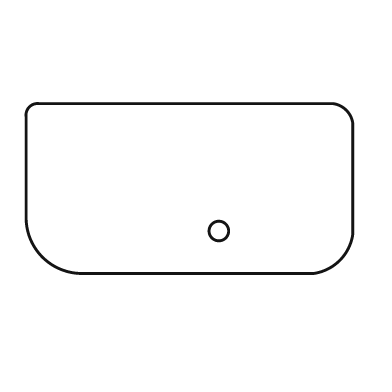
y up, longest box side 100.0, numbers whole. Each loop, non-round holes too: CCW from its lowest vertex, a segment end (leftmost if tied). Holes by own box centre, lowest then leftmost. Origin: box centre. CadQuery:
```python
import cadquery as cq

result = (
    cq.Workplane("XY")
    .moveTo(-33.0, -26.0)
    .lineTo(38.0, -26.0)
    .threePointArc((46.0, -22.0), (50.0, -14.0))
    .lineTo(50.0, 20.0)
    .threePointArc((48.0, 24.0), (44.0, 26.0))
    .lineTo(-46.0, 26.0)
    .threePointArc((-49.0, 25.0), (-50.0, 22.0))
    .lineTo(-50.0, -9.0)
    .threePointArc((-45.0, -21.0), (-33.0, -26.0))
    .close()
    .moveTo(9.0, -13.0)
    .circle(3.0)
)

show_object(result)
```